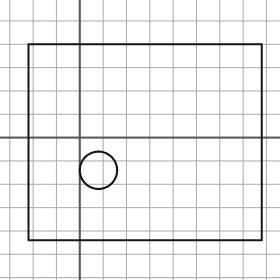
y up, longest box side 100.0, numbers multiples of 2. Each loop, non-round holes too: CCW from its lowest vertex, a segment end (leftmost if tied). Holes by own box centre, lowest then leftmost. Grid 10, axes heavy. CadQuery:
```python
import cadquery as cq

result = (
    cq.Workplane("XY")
    .moveTo(-22.0, -44.0)
    .lineTo(78.0, -44.0)
    .lineTo(78.0, 40.0)
    .lineTo(-22.0, 40.0)
    .close()
    .moveTo(8.0, -14.0)
    .circle(8.0)
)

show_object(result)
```